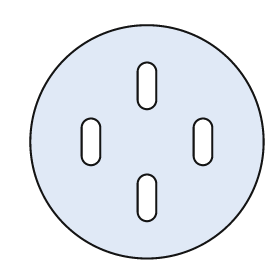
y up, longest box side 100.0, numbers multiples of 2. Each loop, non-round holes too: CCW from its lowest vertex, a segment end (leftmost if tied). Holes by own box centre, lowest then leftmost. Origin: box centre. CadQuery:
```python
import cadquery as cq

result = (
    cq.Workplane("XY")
    .moveTo(0.0, 0.0)
    .circle(50.0)
    .moveTo(-4.0, -30.0)
    .threePointArc((0.0, -34.0), (4.0, -30.0))
    .lineTo(4.0, -18.0)
    .threePointArc((0.0, -14.0), (-4.0, -18.0))
    .close()
    .moveTo(-28.0, -6.0)
    .threePointArc((-24.0, -10.0), (-20.0, -6.0))
    .lineTo(-20.0, 6.0)
    .threePointArc((-24.0, 10.0), (-28.0, 6.0))
    .close()
    .moveTo(20.0, -6.0)
    .threePointArc((24.0, -10.0), (28.0, -6.0))
    .lineTo(28.0, 6.0)
    .threePointArc((24.0, 10.0), (20.0, 6.0))
    .close()
    .moveTo(-4.0, 18.0)
    .threePointArc((0.0, 14.0), (4.0, 18.0))
    .lineTo(4.0, 30.0)
    .threePointArc((0.0, 34.0), (-4.0, 30.0))
    .close()
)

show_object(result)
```